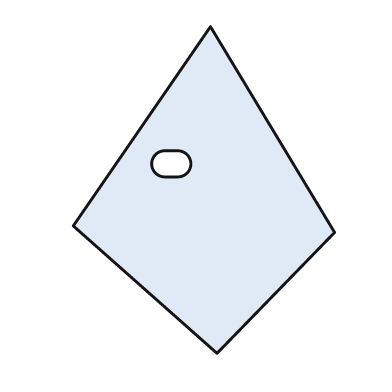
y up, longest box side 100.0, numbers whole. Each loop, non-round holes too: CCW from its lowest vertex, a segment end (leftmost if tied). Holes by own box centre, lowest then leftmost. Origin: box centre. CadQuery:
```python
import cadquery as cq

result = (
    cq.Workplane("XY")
    .moveTo(4.0, -50.0)
    .lineTo(40.0, -13.0)
    .lineTo(2.0, 50.0)
    .lineTo(-40.0, -11.0)
    .close()
    .moveTo(-12.0, 4.0)
    .lineTo(-8.0, 4.0)
    .threePointArc((-4.0, 8.0), (-8.0, 12.0))
    .lineTo(-12.0, 12.0)
    .threePointArc((-16.0, 8.0), (-12.0, 4.0))
    .close()
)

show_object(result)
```